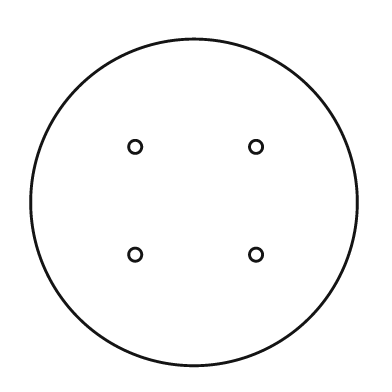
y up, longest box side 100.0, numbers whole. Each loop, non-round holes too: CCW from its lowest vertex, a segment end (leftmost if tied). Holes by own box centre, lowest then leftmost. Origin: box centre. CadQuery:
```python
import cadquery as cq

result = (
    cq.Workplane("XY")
    .moveTo(0.0, 0.0)
    .circle(50.0)
    .moveTo(-18.0, -16.0)
    .circle(2.0)
    .moveTo(19.0, -16.0)
    .circle(2.0)
    .moveTo(-18.0, 17.0)
    .circle(2.0)
    .moveTo(19.0, 17.0)
    .circle(2.0)
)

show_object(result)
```